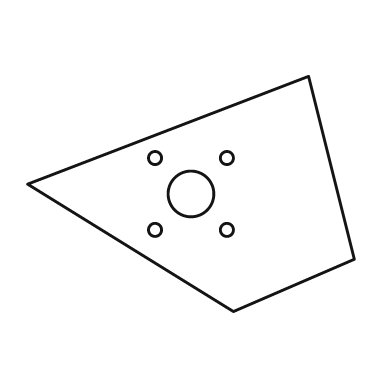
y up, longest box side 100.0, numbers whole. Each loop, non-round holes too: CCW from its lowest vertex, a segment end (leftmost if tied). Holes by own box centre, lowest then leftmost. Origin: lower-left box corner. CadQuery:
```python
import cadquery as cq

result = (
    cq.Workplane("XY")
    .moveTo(63.0, 0.0)
    .lineTo(100.0, 16.0)
    .lineTo(86.0, 72.0)
    .lineTo(0.0, 39.0)
    .close()
    .moveTo(39.0, 25.0)
    .circle(2.0)
    .moveTo(61.0, 25.0)
    .circle(2.0)
    .moveTo(50.0, 36.0)
    .circle(7.0)
    .moveTo(39.0, 47.0)
    .circle(2.0)
    .moveTo(61.0, 47.0)
    .circle(2.0)
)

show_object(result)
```